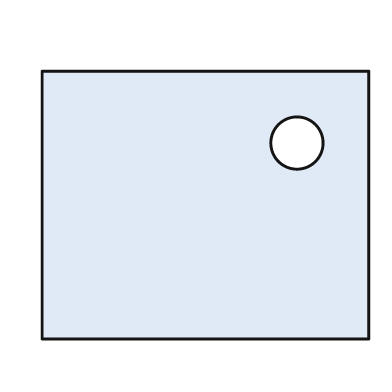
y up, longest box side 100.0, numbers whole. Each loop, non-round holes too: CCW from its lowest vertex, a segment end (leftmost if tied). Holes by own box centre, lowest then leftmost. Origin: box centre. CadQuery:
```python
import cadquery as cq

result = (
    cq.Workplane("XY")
    .moveTo(-50.0, -41.0)
    .lineTo(50.0, -41.0)
    .lineTo(50.0, 41.0)
    .lineTo(-50.0, 41.0)
    .close()
    .moveTo(28.0, 19.0)
    .circle(8.0)
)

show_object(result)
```